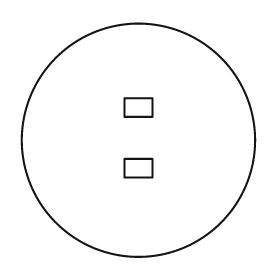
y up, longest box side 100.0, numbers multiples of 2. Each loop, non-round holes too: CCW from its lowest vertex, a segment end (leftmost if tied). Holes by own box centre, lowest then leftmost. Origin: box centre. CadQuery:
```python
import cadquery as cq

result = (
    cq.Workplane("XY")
    .moveTo(0.0, 0.0)
    .circle(50.0)
    .moveTo(-6.0, -16.0)
    .lineTo(6.0, -16.0)
    .lineTo(6.0, -8.0)
    .lineTo(-6.0, -8.0)
    .close()
    .moveTo(-6.0, 10.0)
    .lineTo(6.0, 10.0)
    .lineTo(6.0, 18.0)
    .lineTo(-6.0, 18.0)
    .close()
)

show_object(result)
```